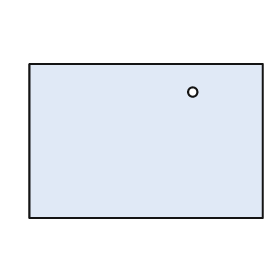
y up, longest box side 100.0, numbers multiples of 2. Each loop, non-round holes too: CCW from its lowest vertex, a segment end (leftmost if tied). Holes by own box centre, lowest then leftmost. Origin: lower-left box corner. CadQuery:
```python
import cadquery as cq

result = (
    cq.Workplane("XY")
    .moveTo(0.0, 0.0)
    .lineTo(100.0, 0.0)
    .lineTo(100.0, 66.0)
    .lineTo(0.0, 66.0)
    .close()
    .moveTo(70.0, 54.0)
    .circle(2.0)
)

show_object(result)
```